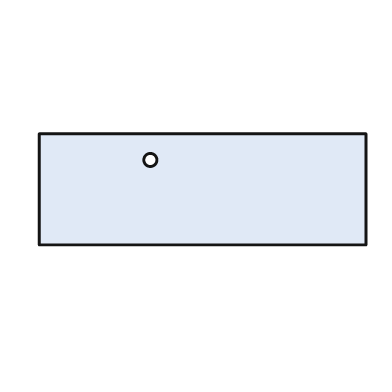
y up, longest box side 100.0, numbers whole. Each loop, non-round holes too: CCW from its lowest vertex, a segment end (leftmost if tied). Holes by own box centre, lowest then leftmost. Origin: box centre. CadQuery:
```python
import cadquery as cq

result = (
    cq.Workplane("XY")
    .moveTo(-50.0, -17.0)
    .lineTo(50.0, -17.0)
    .lineTo(50.0, 17.0)
    .lineTo(-50.0, 17.0)
    .close()
    .moveTo(-16.0, 9.0)
    .circle(2.0)
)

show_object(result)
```